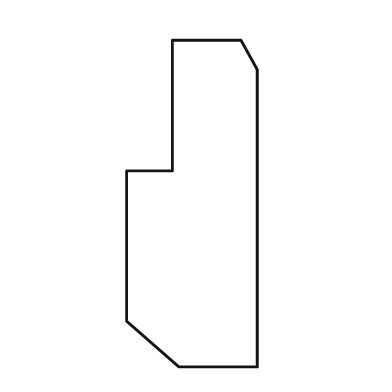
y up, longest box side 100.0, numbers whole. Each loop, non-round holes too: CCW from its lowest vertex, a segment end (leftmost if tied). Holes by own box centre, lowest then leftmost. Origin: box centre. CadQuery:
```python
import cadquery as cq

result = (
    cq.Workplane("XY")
    .moveTo(-4.0, -50.0)
    .lineTo(20.0, -50.0)
    .lineTo(20.0, 41.0)
    .lineTo(15.0, 50.0)
    .lineTo(-6.0, 50.0)
    .lineTo(-6.0, 10.0)
    .lineTo(-20.0, 10.0)
    .lineTo(-20.0, -36.0)
    .close()
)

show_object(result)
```